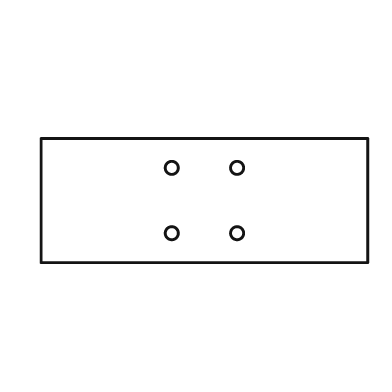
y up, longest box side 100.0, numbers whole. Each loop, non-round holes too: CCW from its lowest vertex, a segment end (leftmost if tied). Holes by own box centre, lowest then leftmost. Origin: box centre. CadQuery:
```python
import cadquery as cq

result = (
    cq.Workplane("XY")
    .moveTo(-50.0, -19.0)
    .lineTo(50.0, -19.0)
    .lineTo(50.0, 19.0)
    .lineTo(-50.0, 19.0)
    .close()
    .moveTo(-10.0, -10.0)
    .circle(2.0)
    .moveTo(10.0, -10.0)
    .circle(2.0)
    .moveTo(-10.0, 10.0)
    .circle(2.0)
    .moveTo(10.0, 10.0)
    .circle(2.0)
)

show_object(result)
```